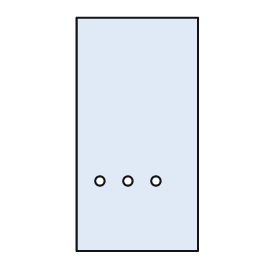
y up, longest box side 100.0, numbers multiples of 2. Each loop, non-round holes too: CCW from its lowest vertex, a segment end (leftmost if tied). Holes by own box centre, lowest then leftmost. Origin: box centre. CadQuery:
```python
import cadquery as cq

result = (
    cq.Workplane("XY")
    .moveTo(-26.0, -50.0)
    .lineTo(26.0, -50.0)
    .lineTo(26.0, 50.0)
    .lineTo(-26.0, 50.0)
    .close()
    .moveTo(-16.0, -20.0)
    .circle(2.0)
    .moveTo(-4.0, -20.0)
    .circle(2.0)
    .moveTo(8.0, -20.0)
    .circle(2.0)
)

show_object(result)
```